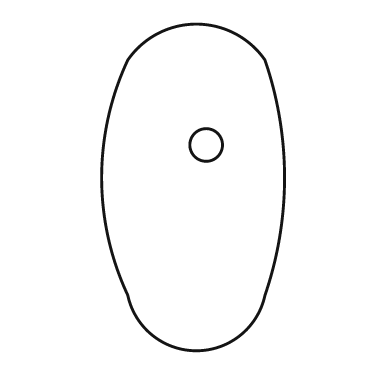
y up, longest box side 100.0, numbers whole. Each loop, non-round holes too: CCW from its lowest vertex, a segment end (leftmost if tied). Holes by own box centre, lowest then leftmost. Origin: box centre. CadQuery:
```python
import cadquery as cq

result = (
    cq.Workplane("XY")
    .moveTo(-20.0, -33.0)
    .threePointArc((1.0, -50.0), (22.0, -33.0))
    .threePointArc((28.0, 3.0), (22.0, 39.0))
    .threePointArc((1.0, 50.0), (-20.0, 39.0))
    .threePointArc((-28.0, 3.0), (-20.0, -33.0))
    .close()
    .moveTo(4.0, 13.0)
    .circle(5.0)
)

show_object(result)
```